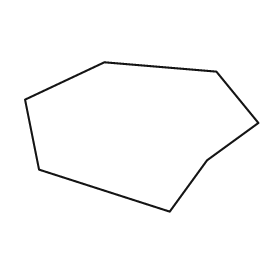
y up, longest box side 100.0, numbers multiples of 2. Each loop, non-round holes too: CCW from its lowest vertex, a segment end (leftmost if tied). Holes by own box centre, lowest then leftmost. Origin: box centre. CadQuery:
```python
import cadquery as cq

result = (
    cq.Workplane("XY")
    .moveTo(12.0, -32.0)
    .lineTo(28.0, -10.0)
    .lineTo(50.0, 6.0)
    .lineTo(32.0, 28.0)
    .lineTo(-16.0, 32.0)
    .lineTo(-50.0, 16.0)
    .lineTo(-44.0, -14.0)
    .close()
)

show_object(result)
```